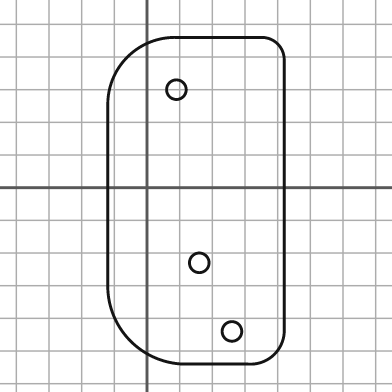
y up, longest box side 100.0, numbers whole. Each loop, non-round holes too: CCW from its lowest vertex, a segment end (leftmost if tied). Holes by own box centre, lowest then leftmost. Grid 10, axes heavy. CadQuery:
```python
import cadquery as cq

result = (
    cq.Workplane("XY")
    .moveTo(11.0, -54.0)
    .lineTo(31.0, -54.0)
    .threePointArc((39.0, -51.0), (42.0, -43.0))
    .lineTo(42.0, 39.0)
    .threePointArc((40.0, 44.0), (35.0, 46.0))
    .lineTo(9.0, 46.0)
    .threePointArc((-6.0, 40.0), (-12.0, 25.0))
    .lineTo(-12.0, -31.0)
    .threePointArc((-5.0, -47.0), (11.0, -54.0))
    .close()
    .moveTo(26.0, -44.0)
    .circle(3.0)
    .moveTo(16.0, -23.0)
    .circle(3.0)
    .moveTo(9.0, 30.0)
    .circle(3.0)
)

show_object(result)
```